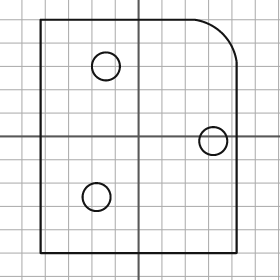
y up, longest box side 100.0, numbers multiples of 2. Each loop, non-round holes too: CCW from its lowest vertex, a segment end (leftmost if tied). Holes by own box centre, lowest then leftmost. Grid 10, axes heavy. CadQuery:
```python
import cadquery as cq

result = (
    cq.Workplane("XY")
    .moveTo(-42.0, -50.0)
    .lineTo(42.0, -50.0)
    .lineTo(42.0, 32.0)
    .threePointArc((36.0, 44.0), (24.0, 50.0))
    .lineTo(-42.0, 50.0)
    .close()
    .moveTo(-18.0, -26.0)
    .circle(6.0)
    .moveTo(32.0, -2.0)
    .circle(6.0)
    .moveTo(-14.0, 30.0)
    .circle(6.0)
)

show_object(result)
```